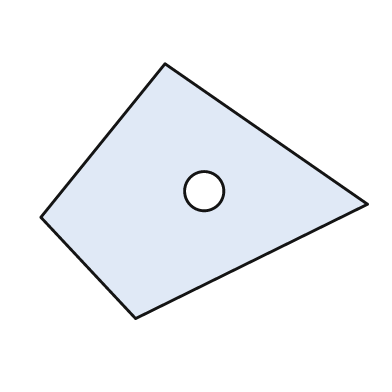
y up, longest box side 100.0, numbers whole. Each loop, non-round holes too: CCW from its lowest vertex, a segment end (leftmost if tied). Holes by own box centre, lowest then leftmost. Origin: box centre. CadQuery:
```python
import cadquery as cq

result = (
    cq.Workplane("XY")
    .moveTo(-21.0, -39.0)
    .lineTo(50.0, -4.0)
    .lineTo(-12.0, 39.0)
    .lineTo(-50.0, -8.0)
    .close()
    .moveTo(0.0, 0.0)
    .circle(6.0)
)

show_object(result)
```